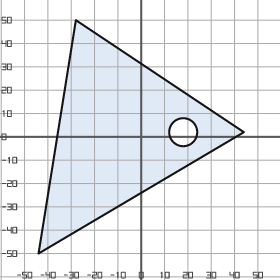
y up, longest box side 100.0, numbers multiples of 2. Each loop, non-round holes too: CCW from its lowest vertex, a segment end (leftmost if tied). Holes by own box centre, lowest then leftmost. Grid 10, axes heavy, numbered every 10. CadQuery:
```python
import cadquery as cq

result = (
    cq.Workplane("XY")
    .moveTo(-44.0, -50.0)
    .lineTo(44.0, 2.0)
    .lineTo(-28.0, 50.0)
    .close()
    .moveTo(18.0, 2.0)
    .circle(6.0)
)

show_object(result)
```